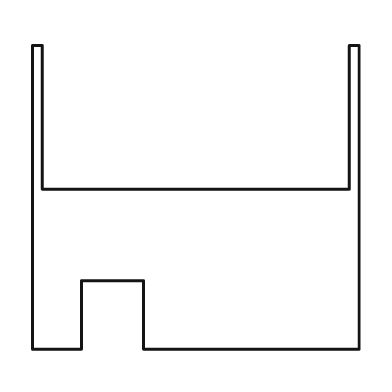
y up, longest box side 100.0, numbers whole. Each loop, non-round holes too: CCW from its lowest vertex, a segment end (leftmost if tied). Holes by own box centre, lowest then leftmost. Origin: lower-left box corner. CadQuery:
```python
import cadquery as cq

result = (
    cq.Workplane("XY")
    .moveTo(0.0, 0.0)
    .lineTo(15.0, 0.0)
    .lineTo(15.0, 21.0)
    .lineTo(34.0, 21.0)
    .lineTo(34.0, 0.0)
    .lineTo(100.0, 0.0)
    .lineTo(100.0, 93.0)
    .lineTo(97.0, 93.0)
    .lineTo(97.0, 49.0)
    .lineTo(3.0, 49.0)
    .lineTo(3.0, 93.0)
    .lineTo(0.0, 93.0)
    .close()
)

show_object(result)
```